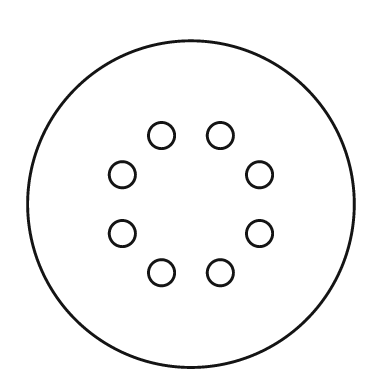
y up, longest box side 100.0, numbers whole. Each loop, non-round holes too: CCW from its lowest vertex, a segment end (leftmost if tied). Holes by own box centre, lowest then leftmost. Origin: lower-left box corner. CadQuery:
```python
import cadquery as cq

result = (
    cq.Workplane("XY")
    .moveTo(50.0, 50.0)
    .circle(50.0)
    .moveTo(41.0, 29.0)
    .circle(4.0)
    .moveTo(59.0, 29.0)
    .circle(4.0)
    .moveTo(29.0, 41.0)
    .circle(4.0)
    .moveTo(71.0, 41.0)
    .circle(4.0)
    .moveTo(29.0, 59.0)
    .circle(4.0)
    .moveTo(71.0, 59.0)
    .circle(4.0)
    .moveTo(41.0, 71.0)
    .circle(4.0)
    .moveTo(59.0, 71.0)
    .circle(4.0)
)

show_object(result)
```